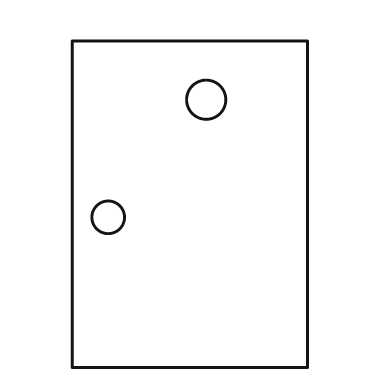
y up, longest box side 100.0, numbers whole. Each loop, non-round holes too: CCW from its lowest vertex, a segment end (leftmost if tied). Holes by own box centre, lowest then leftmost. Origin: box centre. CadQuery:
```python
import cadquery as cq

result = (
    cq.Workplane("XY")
    .moveTo(-36.0, -50.0)
    .lineTo(36.0, -50.0)
    .lineTo(36.0, 50.0)
    .lineTo(-36.0, 50.0)
    .close()
    .moveTo(-25.0, -4.0)
    .circle(5.0)
    .moveTo(5.0, 32.0)
    .circle(6.0)
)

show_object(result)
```